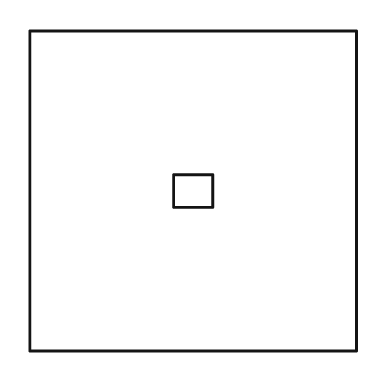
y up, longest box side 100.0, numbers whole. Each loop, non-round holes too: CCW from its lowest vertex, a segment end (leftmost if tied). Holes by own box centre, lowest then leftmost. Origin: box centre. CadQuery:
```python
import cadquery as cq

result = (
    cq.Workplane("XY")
    .moveTo(-50.0, -49.0)
    .lineTo(50.0, -49.0)
    .lineTo(50.0, 49.0)
    .lineTo(-50.0, 49.0)
    .close()
    .moveTo(-6.0, -5.0)
    .lineTo(6.0, -5.0)
    .lineTo(6.0, 5.0)
    .lineTo(-6.0, 5.0)
    .close()
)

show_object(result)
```